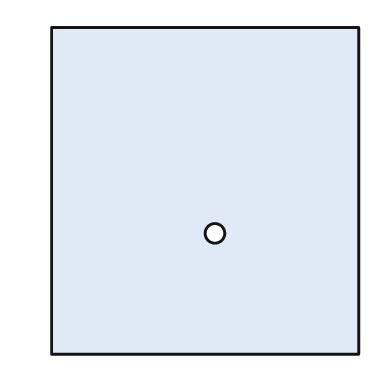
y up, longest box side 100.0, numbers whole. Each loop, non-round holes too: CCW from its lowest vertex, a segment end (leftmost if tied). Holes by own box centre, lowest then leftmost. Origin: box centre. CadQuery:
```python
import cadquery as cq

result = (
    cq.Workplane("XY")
    .moveTo(-47.0, -50.0)
    .lineTo(47.0, -50.0)
    .lineTo(47.0, 50.0)
    .lineTo(-47.0, 50.0)
    .close()
    .moveTo(3.0, -13.0)
    .circle(3.0)
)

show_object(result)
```